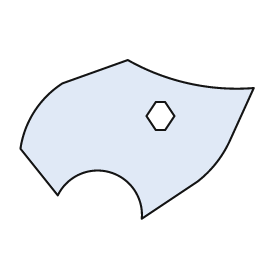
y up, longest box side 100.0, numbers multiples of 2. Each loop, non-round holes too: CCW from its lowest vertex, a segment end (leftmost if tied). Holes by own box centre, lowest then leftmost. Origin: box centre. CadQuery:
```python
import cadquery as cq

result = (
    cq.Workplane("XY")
    .moveTo(2.0, -34.0)
    .lineTo(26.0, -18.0)
    .threePointArc((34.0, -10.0), (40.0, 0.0))
    .lineTo(50.0, 22.0)
    .threePointArc((22.0, 24.0), (-4.0, 34.0))
    .lineTo(-32.0, 24.0)
    .threePointArc((-44.0, 12.0), (-50.0, -4.0))
    .lineTo(-34.0, -24.0)
    .threePointArc((-12.0, -14.0), (2.0, -34.0))
    .close()
    .moveTo(8.0, 4.0)
    .lineTo(12.0, 4.0)
    .lineTo(16.0, 10.0)
    .lineTo(12.0, 16.0)
    .lineTo(8.0, 16.0)
    .lineTo(4.0, 10.0)
    .close()
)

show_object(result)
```